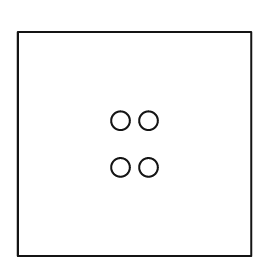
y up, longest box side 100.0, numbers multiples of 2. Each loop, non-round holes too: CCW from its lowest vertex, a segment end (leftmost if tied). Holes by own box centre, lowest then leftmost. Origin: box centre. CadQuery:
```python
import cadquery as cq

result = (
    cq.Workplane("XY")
    .moveTo(-50.0, -48.0)
    .lineTo(50.0, -48.0)
    .lineTo(50.0, 48.0)
    .lineTo(-50.0, 48.0)
    .close()
    .moveTo(-6.0, -10.0)
    .circle(4.0)
    .moveTo(6.0, -10.0)
    .circle(4.0)
    .moveTo(-6.0, 10.0)
    .circle(4.0)
    .moveTo(6.0, 10.0)
    .circle(4.0)
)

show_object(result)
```